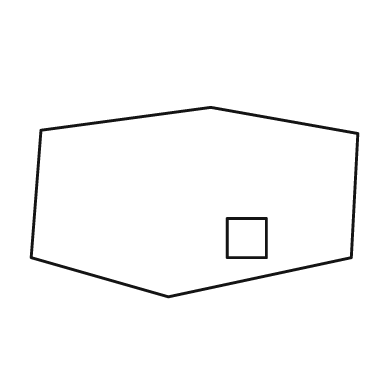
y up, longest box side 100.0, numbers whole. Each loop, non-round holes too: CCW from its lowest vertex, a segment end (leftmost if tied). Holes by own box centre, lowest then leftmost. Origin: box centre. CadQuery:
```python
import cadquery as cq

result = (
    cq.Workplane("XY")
    .moveTo(-8.0, -29.0)
    .lineTo(48.0, -17.0)
    .lineTo(50.0, 21.0)
    .lineTo(5.0, 29.0)
    .lineTo(-47.0, 22.0)
    .lineTo(-50.0, -17.0)
    .close()
    .moveTo(10.0, -17.0)
    .lineTo(22.0, -17.0)
    .lineTo(22.0, -5.0)
    .lineTo(10.0, -5.0)
    .close()
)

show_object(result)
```